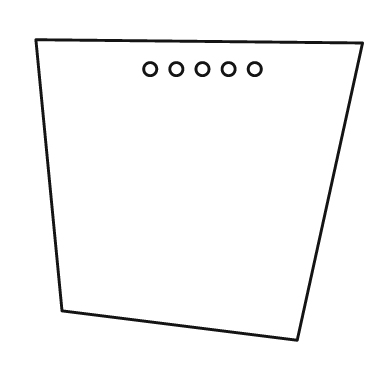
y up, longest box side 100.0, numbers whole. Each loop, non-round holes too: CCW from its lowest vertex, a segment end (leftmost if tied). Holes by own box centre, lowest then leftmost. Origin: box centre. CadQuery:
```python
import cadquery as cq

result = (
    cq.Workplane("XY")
    .moveTo(30.0, -46.0)
    .lineTo(50.0, 45.0)
    .lineTo(-50.0, 46.0)
    .lineTo(-42.0, -37.0)
    .close()
    .moveTo(-15.0, 37.0)
    .circle(2.0)
    .moveTo(-7.0, 37.0)
    .circle(2.0)
    .moveTo(1.0, 37.0)
    .circle(2.0)
    .moveTo(9.0, 37.0)
    .circle(2.0)
    .moveTo(17.0, 37.0)
    .circle(2.0)
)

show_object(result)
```